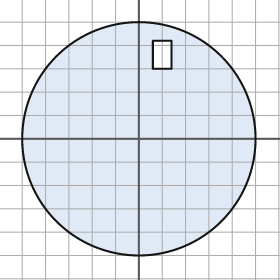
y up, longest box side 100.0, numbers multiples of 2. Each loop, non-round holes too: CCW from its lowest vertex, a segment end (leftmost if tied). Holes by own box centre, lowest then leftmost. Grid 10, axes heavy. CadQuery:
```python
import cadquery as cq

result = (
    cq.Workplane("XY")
    .moveTo(0.0, 0.0)
    .circle(50.0)
    .moveTo(6.0, 30.0)
    .lineTo(14.0, 30.0)
    .lineTo(14.0, 42.0)
    .lineTo(6.0, 42.0)
    .close()
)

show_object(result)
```